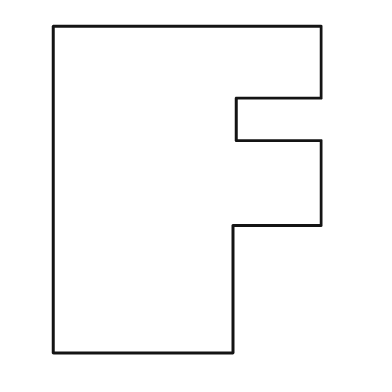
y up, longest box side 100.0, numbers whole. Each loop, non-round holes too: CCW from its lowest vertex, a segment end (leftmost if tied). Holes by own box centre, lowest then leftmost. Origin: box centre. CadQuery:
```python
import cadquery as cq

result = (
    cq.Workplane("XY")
    .moveTo(-41.0, -50.0)
    .lineTo(14.0, -50.0)
    .lineTo(14.0, -11.0)
    .lineTo(41.0, -11.0)
    .lineTo(41.0, 15.0)
    .lineTo(15.0, 15.0)
    .lineTo(15.0, 28.0)
    .lineTo(41.0, 28.0)
    .lineTo(41.0, 50.0)
    .lineTo(-41.0, 50.0)
    .close()
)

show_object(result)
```